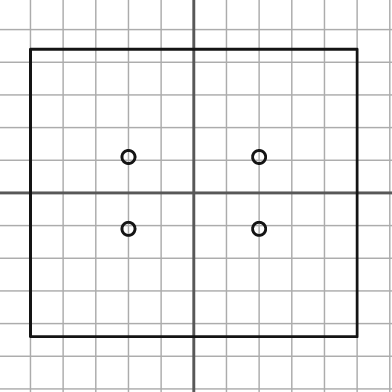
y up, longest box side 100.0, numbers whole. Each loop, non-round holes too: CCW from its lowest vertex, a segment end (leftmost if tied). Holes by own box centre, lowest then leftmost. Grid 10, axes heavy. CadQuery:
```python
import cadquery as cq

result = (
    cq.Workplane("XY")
    .moveTo(-50.0, -44.0)
    .lineTo(50.0, -44.0)
    .lineTo(50.0, 44.0)
    .lineTo(-50.0, 44.0)
    .close()
    .moveTo(-20.0, -11.0)
    .circle(2.0)
    .moveTo(20.0, -11.0)
    .circle(2.0)
    .moveTo(-20.0, 11.0)
    .circle(2.0)
    .moveTo(20.0, 11.0)
    .circle(2.0)
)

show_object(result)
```